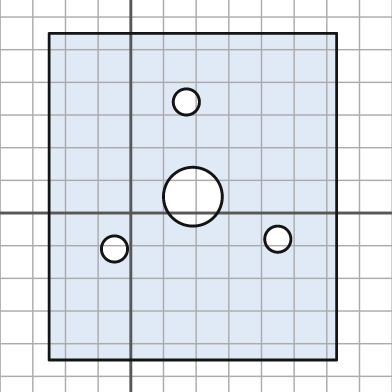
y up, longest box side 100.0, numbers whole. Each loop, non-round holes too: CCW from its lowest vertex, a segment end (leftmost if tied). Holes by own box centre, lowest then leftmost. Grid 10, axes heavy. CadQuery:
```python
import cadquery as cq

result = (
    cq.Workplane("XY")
    .moveTo(-25.0, -45.0)
    .lineTo(63.0, -45.0)
    .lineTo(63.0, 55.0)
    .lineTo(-25.0, 55.0)
    .close()
    .moveTo(-5.0, -11.0)
    .circle(4.0)
    .moveTo(45.0, -8.0)
    .circle(4.0)
    .moveTo(19.0, 5.0)
    .circle(9.0)
    .moveTo(17.0, 34.0)
    .circle(4.0)
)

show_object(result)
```